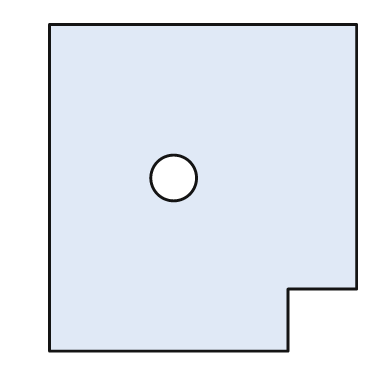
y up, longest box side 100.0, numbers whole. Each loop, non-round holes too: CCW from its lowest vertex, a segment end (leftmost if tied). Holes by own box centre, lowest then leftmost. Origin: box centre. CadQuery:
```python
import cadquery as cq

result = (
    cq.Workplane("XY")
    .moveTo(-47.0, -50.0)
    .lineTo(26.0, -50.0)
    .lineTo(26.0, -31.0)
    .lineTo(47.0, -31.0)
    .lineTo(47.0, 50.0)
    .lineTo(-47.0, 50.0)
    .close()
    .moveTo(-9.0, 3.0)
    .circle(7.0)
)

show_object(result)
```